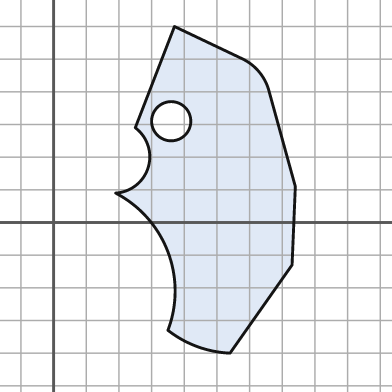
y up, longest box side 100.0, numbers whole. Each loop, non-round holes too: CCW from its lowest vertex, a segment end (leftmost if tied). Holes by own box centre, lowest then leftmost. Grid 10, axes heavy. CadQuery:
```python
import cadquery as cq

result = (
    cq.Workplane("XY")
    .moveTo(54.0, -40.0)
    .lineTo(73.0, -13.0)
    .lineTo(74.0, 11.0)
    .lineTo(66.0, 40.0)
    .threePointArc((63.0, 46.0), (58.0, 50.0))
    .lineTo(37.0, 60.0)
    .lineTo(25.0, 29.0)
    .threePointArc((29.0, 17.0), (19.0, 9.0))
    .threePointArc((35.0, -9.0), (35.0, -33.0))
    .threePointArc((44.0, -38.0), (54.0, -40.0))
    .close()
    .moveTo(36.0, 31.0)
    .circle(6.0)
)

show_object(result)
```